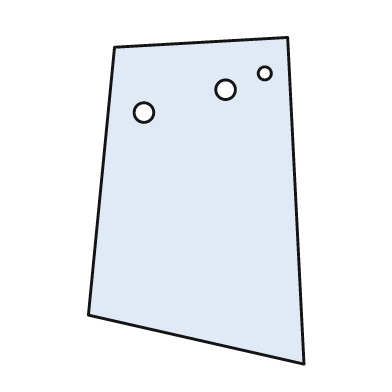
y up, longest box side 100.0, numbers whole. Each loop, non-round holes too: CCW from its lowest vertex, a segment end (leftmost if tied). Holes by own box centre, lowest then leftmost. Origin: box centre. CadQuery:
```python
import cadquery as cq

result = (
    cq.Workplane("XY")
    .moveTo(33.0, -50.0)
    .lineTo(28.0, 50.0)
    .lineTo(-25.0, 47.0)
    .lineTo(-33.0, -35.0)
    .close()
    .moveTo(-16.0, 27.0)
    .circle(3.0)
    .moveTo(9.0, 34.0)
    .circle(3.0)
    .moveTo(21.0, 39.0)
    .circle(2.0)
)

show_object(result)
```